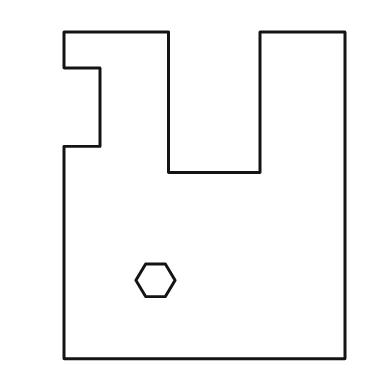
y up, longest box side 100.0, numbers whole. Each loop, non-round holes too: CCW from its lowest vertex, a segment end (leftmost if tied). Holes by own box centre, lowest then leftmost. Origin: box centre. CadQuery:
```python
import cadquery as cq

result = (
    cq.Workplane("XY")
    .moveTo(-43.0, -50.0)
    .lineTo(43.0, -50.0)
    .lineTo(43.0, 50.0)
    .lineTo(17.0, 50.0)
    .lineTo(17.0, 7.0)
    .lineTo(-11.0, 7.0)
    .lineTo(-11.0, 50.0)
    .lineTo(-43.0, 50.0)
    .lineTo(-43.0, 39.0)
    .lineTo(-32.0, 39.0)
    .lineTo(-32.0, 15.0)
    .lineTo(-43.0, 15.0)
    .close()
    .moveTo(-18.0, -31.0)
    .lineTo(-12.0, -31.0)
    .lineTo(-9.0, -26.0)
    .lineTo(-12.0, -21.0)
    .lineTo(-18.0, -21.0)
    .lineTo(-21.0, -26.0)
    .close()
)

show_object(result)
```